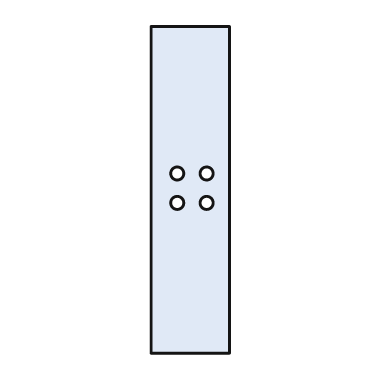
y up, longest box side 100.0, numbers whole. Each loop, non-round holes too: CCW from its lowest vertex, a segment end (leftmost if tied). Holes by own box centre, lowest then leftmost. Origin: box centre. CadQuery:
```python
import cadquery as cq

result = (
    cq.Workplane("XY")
    .moveTo(-12.0, -50.0)
    .lineTo(12.0, -50.0)
    .lineTo(12.0, 50.0)
    .lineTo(-12.0, 50.0)
    .close()
    .moveTo(-4.0, -4.0)
    .circle(2.0)
    .moveTo(5.0, -4.0)
    .circle(2.0)
    .moveTo(-4.0, 5.0)
    .circle(2.0)
    .moveTo(5.0, 5.0)
    .circle(2.0)
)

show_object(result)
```